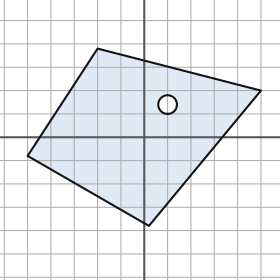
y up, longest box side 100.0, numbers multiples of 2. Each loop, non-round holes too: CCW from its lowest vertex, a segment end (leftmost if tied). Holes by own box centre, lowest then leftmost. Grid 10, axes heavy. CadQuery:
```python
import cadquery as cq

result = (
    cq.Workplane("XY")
    .moveTo(2.0, -38.0)
    .lineTo(50.0, 20.0)
    .lineTo(-20.0, 38.0)
    .lineTo(-50.0, -8.0)
    .close()
    .moveTo(10.0, 14.0)
    .circle(4.0)
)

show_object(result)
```